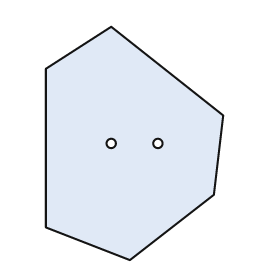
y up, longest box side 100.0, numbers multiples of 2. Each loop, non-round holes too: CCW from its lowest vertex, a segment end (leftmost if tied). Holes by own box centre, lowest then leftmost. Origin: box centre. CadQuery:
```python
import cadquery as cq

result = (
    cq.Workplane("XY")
    .moveTo(-2.0, -50.0)
    .lineTo(34.0, -22.0)
    .lineTo(38.0, 12.0)
    .lineTo(-10.0, 50.0)
    .lineTo(-38.0, 32.0)
    .lineTo(-38.0, -36.0)
    .close()
    .moveTo(-10.0, 0.0)
    .circle(2.0)
    .moveTo(10.0, 0.0)
    .circle(2.0)
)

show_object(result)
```